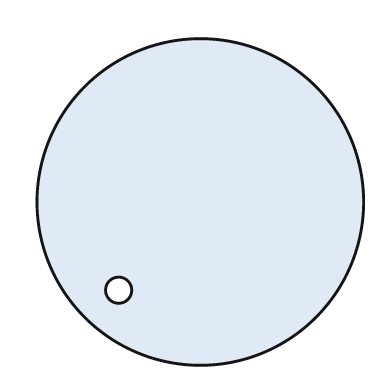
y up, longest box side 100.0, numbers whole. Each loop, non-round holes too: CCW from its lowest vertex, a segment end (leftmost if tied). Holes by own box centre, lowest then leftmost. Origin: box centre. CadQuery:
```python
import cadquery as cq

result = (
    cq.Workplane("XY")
    .moveTo(0.0, 0.0)
    .circle(50.0)
    .moveTo(-25.0, -27.0)
    .circle(4.0)
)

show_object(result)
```